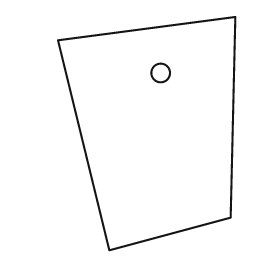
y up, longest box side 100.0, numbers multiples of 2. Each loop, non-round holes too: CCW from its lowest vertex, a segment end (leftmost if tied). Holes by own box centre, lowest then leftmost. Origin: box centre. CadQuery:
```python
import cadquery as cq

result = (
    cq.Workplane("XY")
    .moveTo(-16.0, -50.0)
    .lineTo(36.0, -36.0)
    .lineTo(38.0, 50.0)
    .lineTo(-38.0, 40.0)
    .close()
    .moveTo(6.0, 26.0)
    .circle(4.0)
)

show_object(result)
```